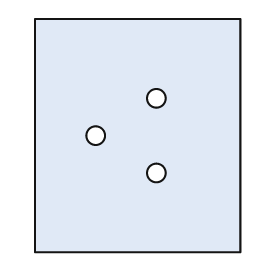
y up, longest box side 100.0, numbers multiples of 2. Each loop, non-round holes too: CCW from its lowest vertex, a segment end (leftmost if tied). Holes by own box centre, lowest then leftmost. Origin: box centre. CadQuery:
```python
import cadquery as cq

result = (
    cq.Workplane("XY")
    .moveTo(-44.0, -50.0)
    .lineTo(44.0, -50.0)
    .lineTo(44.0, 50.0)
    .lineTo(-44.0, 50.0)
    .close()
    .moveTo(8.0, -16.0)
    .circle(4.0)
    .moveTo(-18.0, 0.0)
    .circle(4.0)
    .moveTo(8.0, 16.0)
    .circle(4.0)
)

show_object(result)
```